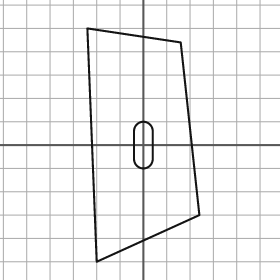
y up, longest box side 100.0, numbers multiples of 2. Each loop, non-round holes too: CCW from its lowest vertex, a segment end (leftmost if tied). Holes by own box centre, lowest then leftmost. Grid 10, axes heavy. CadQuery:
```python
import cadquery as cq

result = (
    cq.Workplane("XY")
    .moveTo(-20.0, -50.0)
    .lineTo(24.0, -30.0)
    .lineTo(16.0, 44.0)
    .lineTo(-24.0, 50.0)
    .close()
    .moveTo(-4.0, -6.0)
    .threePointArc((0.0, -10.0), (4.0, -6.0))
    .lineTo(4.0, 6.0)
    .threePointArc((0.0, 10.0), (-4.0, 6.0))
    .close()
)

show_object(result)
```